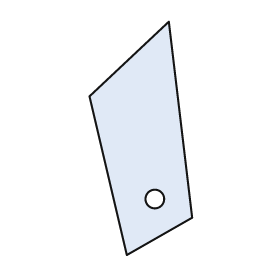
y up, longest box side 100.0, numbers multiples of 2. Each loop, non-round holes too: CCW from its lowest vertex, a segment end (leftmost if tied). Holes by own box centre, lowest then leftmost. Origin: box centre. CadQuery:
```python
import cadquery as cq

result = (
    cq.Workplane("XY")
    .moveTo(-6.0, -50.0)
    .lineTo(22.0, -34.0)
    .lineTo(12.0, 50.0)
    .lineTo(-22.0, 18.0)
    .close()
    .moveTo(6.0, -26.0)
    .circle(4.0)
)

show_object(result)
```